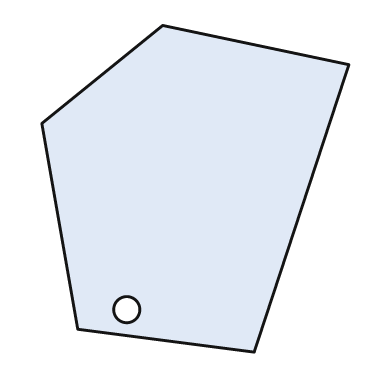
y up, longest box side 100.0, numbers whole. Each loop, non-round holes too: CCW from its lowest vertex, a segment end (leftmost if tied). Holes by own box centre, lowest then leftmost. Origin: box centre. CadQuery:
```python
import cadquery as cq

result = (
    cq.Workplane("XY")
    .moveTo(18.0, -50.0)
    .lineTo(47.0, 38.0)
    .lineTo(-10.0, 50.0)
    .lineTo(-47.0, 20.0)
    .lineTo(-36.0, -43.0)
    .close()
    .moveTo(-21.0, -37.0)
    .circle(4.0)
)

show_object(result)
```